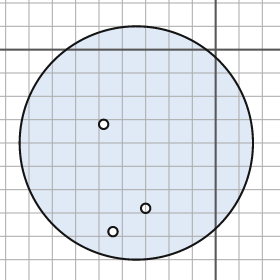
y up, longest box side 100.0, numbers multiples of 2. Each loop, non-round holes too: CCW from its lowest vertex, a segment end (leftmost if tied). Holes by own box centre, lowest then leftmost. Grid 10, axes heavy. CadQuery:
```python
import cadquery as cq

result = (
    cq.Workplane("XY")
    .moveTo(-34.0, -40.0)
    .circle(50.0)
    .moveTo(-44.0, -78.0)
    .circle(2.0)
    .moveTo(-30.0, -68.0)
    .circle(2.0)
    .moveTo(-48.0, -32.0)
    .circle(2.0)
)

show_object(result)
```